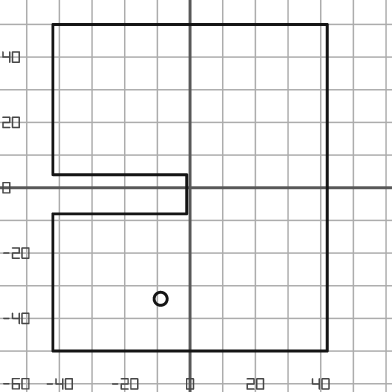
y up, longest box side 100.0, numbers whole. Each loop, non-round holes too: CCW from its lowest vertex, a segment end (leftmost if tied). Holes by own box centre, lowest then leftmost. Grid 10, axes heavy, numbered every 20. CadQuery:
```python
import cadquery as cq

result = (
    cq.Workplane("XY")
    .moveTo(-42.0, -50.0)
    .lineTo(42.0, -50.0)
    .lineTo(42.0, 50.0)
    .lineTo(-42.0, 50.0)
    .lineTo(-42.0, 4.0)
    .lineTo(-1.0, 4.0)
    .lineTo(-1.0, -8.0)
    .lineTo(-42.0, -8.0)
    .close()
    .moveTo(-9.0, -34.0)
    .circle(2.0)
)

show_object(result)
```